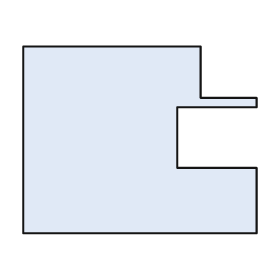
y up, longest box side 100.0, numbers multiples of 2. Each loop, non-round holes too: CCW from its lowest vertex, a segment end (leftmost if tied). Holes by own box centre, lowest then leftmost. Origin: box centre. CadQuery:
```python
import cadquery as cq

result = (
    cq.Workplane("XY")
    .moveTo(-50.0, -40.0)
    .lineTo(50.0, -40.0)
    .lineTo(50.0, -12.0)
    .lineTo(16.0, -12.0)
    .lineTo(16.0, 14.0)
    .lineTo(50.0, 14.0)
    .lineTo(50.0, 18.0)
    .lineTo(26.0, 18.0)
    .lineTo(26.0, 40.0)
    .lineTo(-50.0, 40.0)
    .close()
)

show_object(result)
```